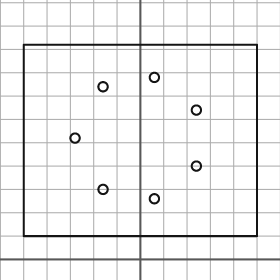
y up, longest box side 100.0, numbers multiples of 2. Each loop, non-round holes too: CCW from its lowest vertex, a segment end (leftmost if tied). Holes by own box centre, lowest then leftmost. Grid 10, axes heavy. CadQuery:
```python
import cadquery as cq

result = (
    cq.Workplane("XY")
    .moveTo(-50.0, 10.0)
    .lineTo(50.0, 10.0)
    .lineTo(50.0, 92.0)
    .lineTo(-50.0, 92.0)
    .close()
    .moveTo(6.0, 26.0)
    .circle(2.0)
    .moveTo(-16.0, 30.0)
    .circle(2.0)
    .moveTo(24.0, 40.0)
    .circle(2.0)
    .moveTo(-28.0, 52.0)
    .circle(2.0)
    .moveTo(24.0, 64.0)
    .circle(2.0)
    .moveTo(-16.0, 74.0)
    .circle(2.0)
    .moveTo(6.0, 78.0)
    .circle(2.0)
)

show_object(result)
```